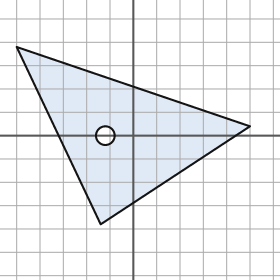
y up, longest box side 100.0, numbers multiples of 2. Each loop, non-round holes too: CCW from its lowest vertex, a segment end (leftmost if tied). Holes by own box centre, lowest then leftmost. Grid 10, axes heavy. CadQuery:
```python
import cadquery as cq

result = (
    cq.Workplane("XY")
    .moveTo(-14.0, -38.0)
    .lineTo(50.0, 4.0)
    .lineTo(-50.0, 38.0)
    .close()
    .moveTo(-12.0, 0.0)
    .circle(4.0)
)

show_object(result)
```